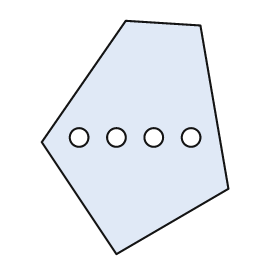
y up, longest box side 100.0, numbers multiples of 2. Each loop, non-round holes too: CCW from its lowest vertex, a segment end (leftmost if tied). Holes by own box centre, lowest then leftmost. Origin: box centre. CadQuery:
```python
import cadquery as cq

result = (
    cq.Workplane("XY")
    .moveTo(-8.0, -50.0)
    .lineTo(40.0, -22.0)
    .lineTo(28.0, 48.0)
    .lineTo(-4.0, 50.0)
    .lineTo(-40.0, -2.0)
    .close()
    .moveTo(-24.0, 0.0)
    .circle(4.0)
    .moveTo(-8.0, 0.0)
    .circle(4.0)
    .moveTo(8.0, 0.0)
    .circle(4.0)
    .moveTo(24.0, 0.0)
    .circle(4.0)
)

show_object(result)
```